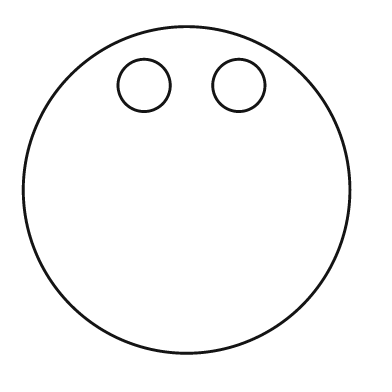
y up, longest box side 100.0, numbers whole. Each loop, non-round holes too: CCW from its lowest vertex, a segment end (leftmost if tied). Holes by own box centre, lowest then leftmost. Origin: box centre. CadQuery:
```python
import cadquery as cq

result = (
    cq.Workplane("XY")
    .moveTo(0.0, 0.0)
    .circle(50.0)
    .moveTo(-13.0, 32.0)
    .circle(8.0)
    .moveTo(16.0, 32.0)
    .circle(8.0)
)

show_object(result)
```